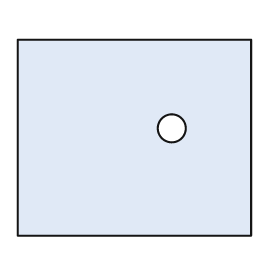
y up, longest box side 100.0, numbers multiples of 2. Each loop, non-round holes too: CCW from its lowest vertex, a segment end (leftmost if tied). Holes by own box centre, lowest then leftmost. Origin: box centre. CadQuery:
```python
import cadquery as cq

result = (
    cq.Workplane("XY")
    .moveTo(-50.0, -42.0)
    .lineTo(50.0, -42.0)
    .lineTo(50.0, 42.0)
    .lineTo(-50.0, 42.0)
    .close()
    .moveTo(16.0, 4.0)
    .circle(6.0)
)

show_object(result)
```